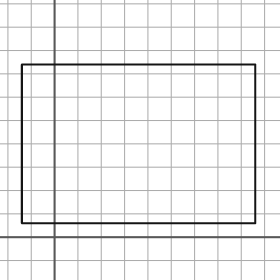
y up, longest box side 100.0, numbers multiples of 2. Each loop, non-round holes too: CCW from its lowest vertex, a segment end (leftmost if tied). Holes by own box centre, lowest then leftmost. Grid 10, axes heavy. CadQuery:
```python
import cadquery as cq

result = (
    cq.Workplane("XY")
    .moveTo(-14.0, 6.0)
    .lineTo(86.0, 6.0)
    .lineTo(86.0, 74.0)
    .lineTo(-14.0, 74.0)
    .close()
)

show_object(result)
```